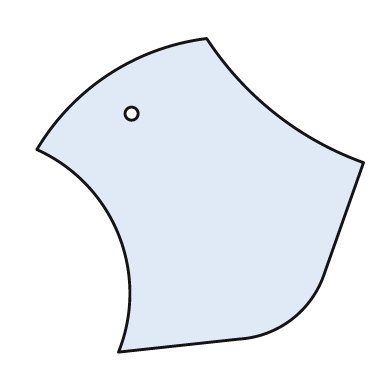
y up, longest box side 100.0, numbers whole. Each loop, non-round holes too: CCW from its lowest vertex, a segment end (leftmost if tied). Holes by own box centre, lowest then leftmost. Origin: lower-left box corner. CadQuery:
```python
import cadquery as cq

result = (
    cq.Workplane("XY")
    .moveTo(25.0, 0.0)
    .lineTo(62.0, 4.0)
    .threePointArc((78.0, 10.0), (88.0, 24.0))
    .lineTo(100.0, 58.0)
    .threePointArc((73.0, 73.0), (52.0, 96.0))
    .threePointArc((22.0, 85.0), (0.0, 62.0))
    .threePointArc((25.0, 36.0), (25.0, 0.0))
    .close()
    .moveTo(29.0, 73.0)
    .circle(2.0)
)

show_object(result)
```